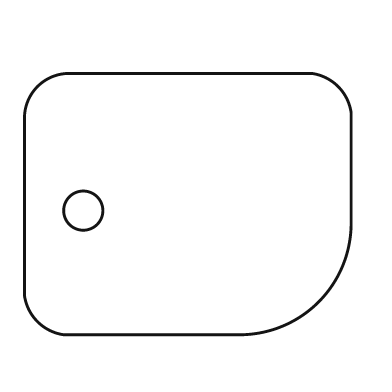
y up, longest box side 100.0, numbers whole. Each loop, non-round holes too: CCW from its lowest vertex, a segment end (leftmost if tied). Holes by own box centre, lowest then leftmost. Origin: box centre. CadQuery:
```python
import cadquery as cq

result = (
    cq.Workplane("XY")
    .moveTo(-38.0, -40.0)
    .lineTo(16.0, -40.0)
    .threePointArc((40.0, -30.0), (50.0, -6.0))
    .lineTo(50.0, 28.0)
    .threePointArc((46.0, 36.0), (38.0, 40.0))
    .lineTo(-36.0, 40.0)
    .threePointArc((-46.0, 36.0), (-50.0, 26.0))
    .lineTo(-50.0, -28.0)
    .threePointArc((-46.0, -36.0), (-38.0, -40.0))
    .close()
    .moveTo(-32.0, -2.0)
    .circle(6.0)
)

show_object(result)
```